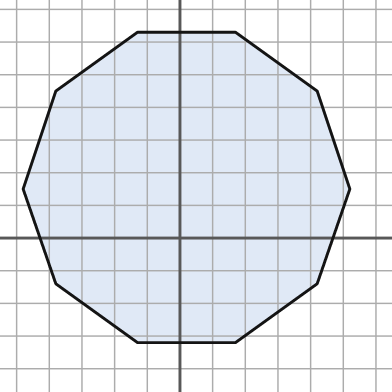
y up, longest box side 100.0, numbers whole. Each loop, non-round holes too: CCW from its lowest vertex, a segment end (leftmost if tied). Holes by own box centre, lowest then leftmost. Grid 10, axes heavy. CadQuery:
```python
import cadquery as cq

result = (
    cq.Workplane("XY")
    .moveTo(-13.0, -32.0)
    .lineTo(17.0, -32.0)
    .lineTo(42.0, -14.0)
    .lineTo(52.0, 15.0)
    .lineTo(42.0, 45.0)
    .lineTo(17.0, 63.0)
    .lineTo(-13.0, 63.0)
    .lineTo(-38.0, 45.0)
    .lineTo(-48.0, 15.0)
    .lineTo(-38.0, -14.0)
    .close()
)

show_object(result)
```